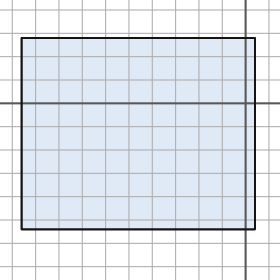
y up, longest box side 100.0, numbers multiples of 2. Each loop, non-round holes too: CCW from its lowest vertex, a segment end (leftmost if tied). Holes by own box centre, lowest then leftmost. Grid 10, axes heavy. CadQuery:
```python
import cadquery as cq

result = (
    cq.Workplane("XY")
    .moveTo(-96.0, -54.0)
    .lineTo(4.0, -54.0)
    .lineTo(4.0, 28.0)
    .lineTo(-96.0, 28.0)
    .close()
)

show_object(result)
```